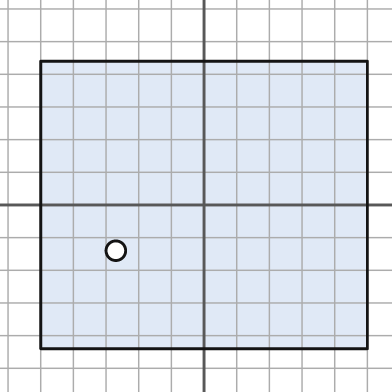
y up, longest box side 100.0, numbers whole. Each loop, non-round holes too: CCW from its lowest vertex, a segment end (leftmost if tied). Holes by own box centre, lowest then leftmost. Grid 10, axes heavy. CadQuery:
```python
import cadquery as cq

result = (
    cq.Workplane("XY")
    .moveTo(-50.0, -44.0)
    .lineTo(50.0, -44.0)
    .lineTo(50.0, 44.0)
    .lineTo(-50.0, 44.0)
    .close()
    .moveTo(-27.0, -14.0)
    .circle(3.0)
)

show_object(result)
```